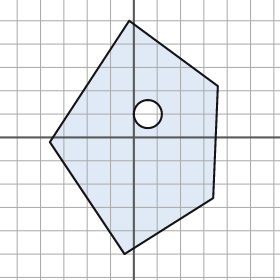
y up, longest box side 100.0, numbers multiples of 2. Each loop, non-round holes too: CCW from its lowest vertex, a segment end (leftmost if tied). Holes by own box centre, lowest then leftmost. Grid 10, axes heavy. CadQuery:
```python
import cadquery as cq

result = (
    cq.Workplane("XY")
    .moveTo(-4.0, -50.0)
    .lineTo(34.0, -26.0)
    .lineTo(36.0, 22.0)
    .lineTo(-2.0, 50.0)
    .lineTo(-36.0, -2.0)
    .close()
    .moveTo(6.0, 10.0)
    .circle(6.0)
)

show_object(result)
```